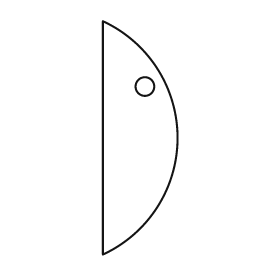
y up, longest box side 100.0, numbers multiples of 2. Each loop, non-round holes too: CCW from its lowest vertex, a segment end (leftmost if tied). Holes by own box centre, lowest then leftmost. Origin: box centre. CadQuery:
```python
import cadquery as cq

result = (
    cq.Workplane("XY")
    .moveTo(-16.0, -50.0)
    .threePointArc((16.0, 0.0), (-16.0, 50.0))
    .close()
    .moveTo(2.0, 22.0)
    .circle(4.0)
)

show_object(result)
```